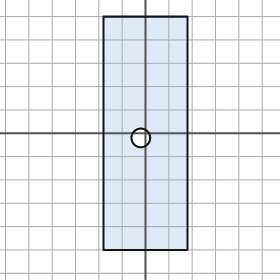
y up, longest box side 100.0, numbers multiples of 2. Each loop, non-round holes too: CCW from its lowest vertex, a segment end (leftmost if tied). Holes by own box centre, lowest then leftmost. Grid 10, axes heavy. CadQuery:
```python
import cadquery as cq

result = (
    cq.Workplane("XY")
    .moveTo(-18.0, -50.0)
    .lineTo(18.0, -50.0)
    .lineTo(18.0, 50.0)
    .lineTo(-18.0, 50.0)
    .close()
    .moveTo(-2.0, -2.0)
    .circle(4.0)
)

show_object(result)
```